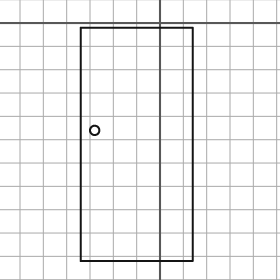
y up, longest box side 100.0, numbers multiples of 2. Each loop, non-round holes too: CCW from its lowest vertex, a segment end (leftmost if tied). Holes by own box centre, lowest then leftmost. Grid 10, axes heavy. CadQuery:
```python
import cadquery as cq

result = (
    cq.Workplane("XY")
    .moveTo(-34.0, -102.0)
    .lineTo(14.0, -102.0)
    .lineTo(14.0, -2.0)
    .lineTo(-34.0, -2.0)
    .close()
    .moveTo(-28.0, -46.0)
    .circle(2.0)
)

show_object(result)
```